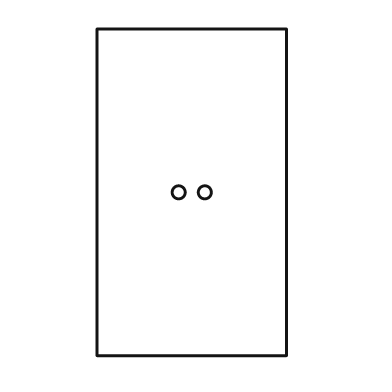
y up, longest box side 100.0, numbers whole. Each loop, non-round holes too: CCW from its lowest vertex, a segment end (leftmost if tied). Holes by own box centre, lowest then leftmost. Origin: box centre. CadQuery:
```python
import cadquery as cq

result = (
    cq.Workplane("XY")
    .moveTo(-29.0, -50.0)
    .lineTo(29.0, -50.0)
    .lineTo(29.0, 50.0)
    .lineTo(-29.0, 50.0)
    .close()
    .moveTo(-4.0, 0.0)
    .circle(2.0)
    .moveTo(4.0, 0.0)
    .circle(2.0)
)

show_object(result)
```